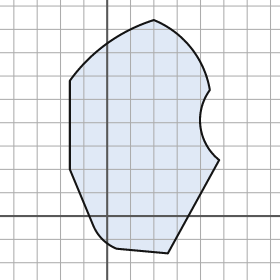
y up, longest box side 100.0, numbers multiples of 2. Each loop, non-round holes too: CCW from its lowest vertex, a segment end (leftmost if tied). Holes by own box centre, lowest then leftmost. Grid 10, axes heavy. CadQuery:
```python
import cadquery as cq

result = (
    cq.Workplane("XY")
    .moveTo(26.0, -16.0)
    .lineTo(48.0, 24.0)
    .threePointArc((40.0, 38.0), (44.0, 54.0))
    .threePointArc((36.0, 72.0), (20.0, 84.0))
    .threePointArc((0.0, 74.0), (-16.0, 58.0))
    .lineTo(-16.0, 20.0)
    .lineTo(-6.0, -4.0)
    .threePointArc((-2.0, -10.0), (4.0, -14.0))
    .close()
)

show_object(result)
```